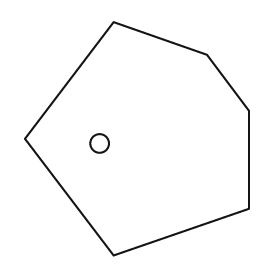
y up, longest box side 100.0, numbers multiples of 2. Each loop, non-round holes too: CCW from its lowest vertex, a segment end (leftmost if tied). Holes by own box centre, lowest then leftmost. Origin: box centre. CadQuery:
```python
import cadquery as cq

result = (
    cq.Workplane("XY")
    .moveTo(-10.0, -50.0)
    .lineTo(48.0, -30.0)
    .lineTo(48.0, 12.0)
    .lineTo(30.0, 36.0)
    .lineTo(-10.0, 50.0)
    .lineTo(-48.0, 0.0)
    .close()
    .moveTo(-16.0, -2.0)
    .circle(4.0)
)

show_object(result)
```